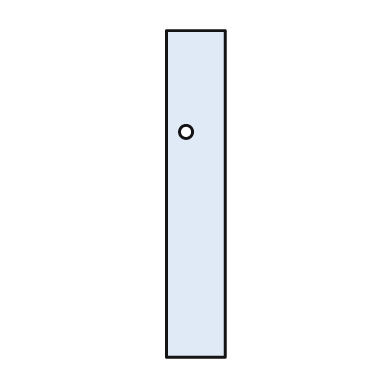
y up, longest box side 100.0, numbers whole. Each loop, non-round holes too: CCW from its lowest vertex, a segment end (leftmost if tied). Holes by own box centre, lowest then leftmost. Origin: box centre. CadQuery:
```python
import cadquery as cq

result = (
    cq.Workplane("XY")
    .moveTo(-9.0, -50.0)
    .lineTo(9.0, -50.0)
    .lineTo(9.0, 50.0)
    .lineTo(-9.0, 50.0)
    .close()
    .moveTo(-3.0, 19.0)
    .circle(2.0)
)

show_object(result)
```